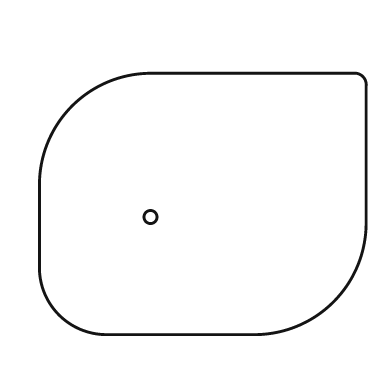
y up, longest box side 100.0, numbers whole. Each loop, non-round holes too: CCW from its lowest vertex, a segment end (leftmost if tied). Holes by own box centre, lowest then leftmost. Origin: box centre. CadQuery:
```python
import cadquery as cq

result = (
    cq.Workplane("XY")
    .moveTo(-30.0, -40.0)
    .lineTo(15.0, -40.0)
    .threePointArc((40.0, -30.0), (50.0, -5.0))
    .lineTo(50.0, 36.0)
    .threePointArc((49.0, 39.0), (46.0, 40.0))
    .lineTo(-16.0, 40.0)
    .threePointArc((-40.0, 30.0), (-50.0, 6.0))
    .lineTo(-50.0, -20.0)
    .threePointArc((-44.0, -34.0), (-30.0, -40.0))
    .close()
    .moveTo(-16.0, -4.0)
    .circle(2.0)
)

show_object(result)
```